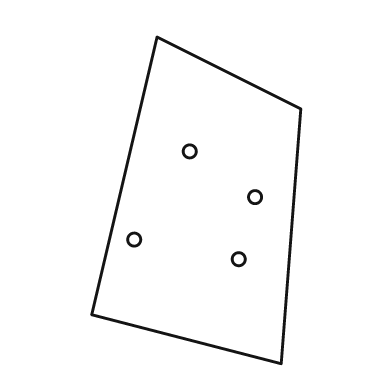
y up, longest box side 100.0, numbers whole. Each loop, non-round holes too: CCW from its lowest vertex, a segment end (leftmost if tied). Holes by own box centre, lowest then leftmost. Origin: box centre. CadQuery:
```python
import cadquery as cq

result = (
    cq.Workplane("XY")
    .moveTo(26.0, -50.0)
    .lineTo(32.0, 28.0)
    .lineTo(-12.0, 50.0)
    .lineTo(-32.0, -35.0)
    .close()
    .moveTo(13.0, -18.0)
    .circle(2.0)
    .moveTo(-19.0, -12.0)
    .circle(2.0)
    .moveTo(18.0, 1.0)
    .circle(2.0)
    .moveTo(-2.0, 15.0)
    .circle(2.0)
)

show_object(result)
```